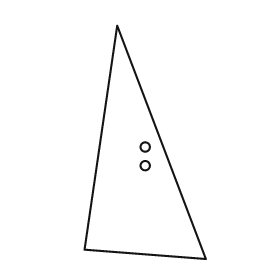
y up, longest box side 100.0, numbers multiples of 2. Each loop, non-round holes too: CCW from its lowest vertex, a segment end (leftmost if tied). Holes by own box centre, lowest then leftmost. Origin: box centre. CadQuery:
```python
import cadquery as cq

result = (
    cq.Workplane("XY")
    .moveTo(26.0, -50.0)
    .lineTo(-12.0, 50.0)
    .lineTo(-26.0, -46.0)
    .close()
    .moveTo(0.0, -10.0)
    .circle(2.0)
    .moveTo(0.0, -2.0)
    .circle(2.0)
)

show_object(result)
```